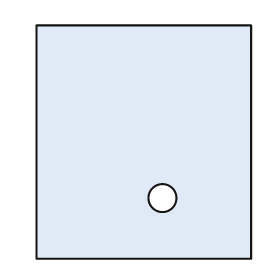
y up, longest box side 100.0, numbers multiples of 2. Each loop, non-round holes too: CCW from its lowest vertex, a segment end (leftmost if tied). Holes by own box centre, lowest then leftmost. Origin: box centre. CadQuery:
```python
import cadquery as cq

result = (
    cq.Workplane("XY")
    .moveTo(-46.0, -50.0)
    .lineTo(46.0, -50.0)
    .lineTo(46.0, 50.0)
    .lineTo(-46.0, 50.0)
    .close()
    .moveTo(8.0, -24.0)
    .circle(6.0)
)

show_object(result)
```